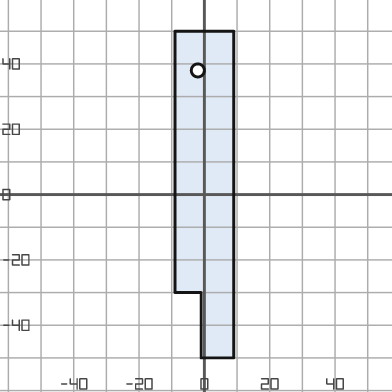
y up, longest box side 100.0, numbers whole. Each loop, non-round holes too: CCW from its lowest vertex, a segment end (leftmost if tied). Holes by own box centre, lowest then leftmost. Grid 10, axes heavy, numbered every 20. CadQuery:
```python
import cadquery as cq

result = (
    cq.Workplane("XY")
    .moveTo(-1.0, -50.0)
    .lineTo(9.0, -50.0)
    .lineTo(9.0, 50.0)
    .lineTo(-9.0, 50.0)
    .lineTo(-9.0, -30.0)
    .lineTo(-1.0, -30.0)
    .close()
    .moveTo(-2.0, 38.0)
    .circle(2.0)
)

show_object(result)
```